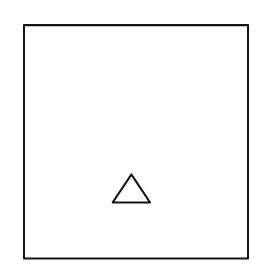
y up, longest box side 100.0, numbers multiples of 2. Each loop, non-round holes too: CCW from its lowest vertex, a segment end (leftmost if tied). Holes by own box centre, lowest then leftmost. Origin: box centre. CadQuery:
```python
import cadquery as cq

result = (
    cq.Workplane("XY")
    .moveTo(-48.0, -50.0)
    .lineTo(48.0, -50.0)
    .lineTo(48.0, 50.0)
    .lineTo(-48.0, 50.0)
    .close()
    .moveTo(-10.0, -26.0)
    .lineTo(6.0, -26.0)
    .lineTo(-2.0, -14.0)
    .close()
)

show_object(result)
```